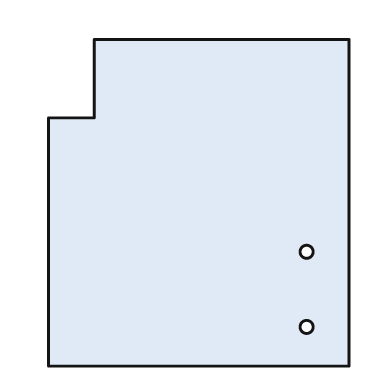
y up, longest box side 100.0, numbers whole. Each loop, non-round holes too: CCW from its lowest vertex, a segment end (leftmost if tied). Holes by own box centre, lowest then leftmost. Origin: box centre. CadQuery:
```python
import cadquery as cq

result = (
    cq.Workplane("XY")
    .moveTo(-46.0, -50.0)
    .lineTo(46.0, -50.0)
    .lineTo(46.0, 50.0)
    .lineTo(-32.0, 50.0)
    .lineTo(-32.0, 26.0)
    .lineTo(-46.0, 26.0)
    .close()
    .moveTo(33.0, -38.0)
    .circle(2.0)
    .moveTo(33.0, -15.0)
    .circle(2.0)
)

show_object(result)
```